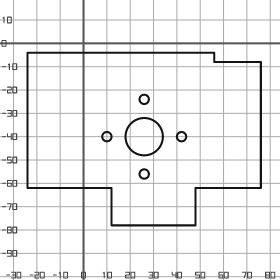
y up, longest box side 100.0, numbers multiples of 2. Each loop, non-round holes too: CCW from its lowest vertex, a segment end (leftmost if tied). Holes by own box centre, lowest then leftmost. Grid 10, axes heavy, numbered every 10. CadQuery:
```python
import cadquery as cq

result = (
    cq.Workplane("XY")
    .moveTo(12.0, -78.0)
    .lineTo(48.0, -78.0)
    .lineTo(48.0, -62.0)
    .lineTo(76.0, -62.0)
    .lineTo(76.0, -8.0)
    .lineTo(56.0, -8.0)
    .lineTo(56.0, -4.0)
    .lineTo(-24.0, -4.0)
    .lineTo(-24.0, -62.0)
    .lineTo(12.0, -62.0)
    .close()
    .moveTo(26.0, -56.0)
    .circle(2.0)
    .moveTo(10.0, -40.0)
    .circle(2.0)
    .moveTo(26.0, -40.0)
    .circle(8.0)
    .moveTo(42.0, -40.0)
    .circle(2.0)
    .moveTo(26.0, -24.0)
    .circle(2.0)
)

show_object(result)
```